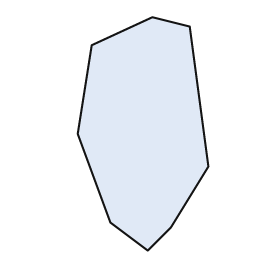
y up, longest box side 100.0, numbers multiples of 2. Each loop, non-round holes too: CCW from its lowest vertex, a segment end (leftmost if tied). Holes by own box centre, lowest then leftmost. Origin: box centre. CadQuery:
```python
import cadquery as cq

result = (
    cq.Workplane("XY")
    .moveTo(2.0, -50.0)
    .lineTo(12.0, -40.0)
    .lineTo(28.0, -14.0)
    .lineTo(20.0, 46.0)
    .lineTo(4.0, 50.0)
    .lineTo(-22.0, 38.0)
    .lineTo(-28.0, 0.0)
    .lineTo(-14.0, -38.0)
    .close()
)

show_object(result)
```